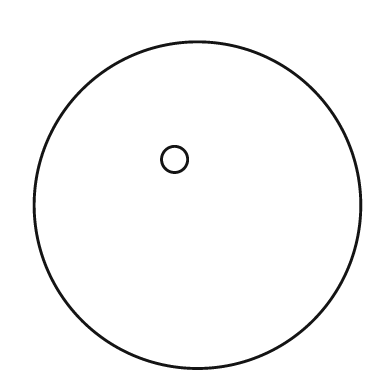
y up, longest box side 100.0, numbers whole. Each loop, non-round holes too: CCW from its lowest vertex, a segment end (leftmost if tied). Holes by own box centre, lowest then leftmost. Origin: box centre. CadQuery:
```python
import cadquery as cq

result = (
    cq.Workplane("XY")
    .moveTo(0.0, 0.0)
    .circle(50.0)
    .moveTo(-7.0, 14.0)
    .circle(4.0)
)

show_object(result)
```